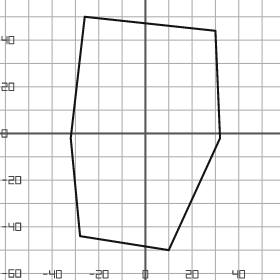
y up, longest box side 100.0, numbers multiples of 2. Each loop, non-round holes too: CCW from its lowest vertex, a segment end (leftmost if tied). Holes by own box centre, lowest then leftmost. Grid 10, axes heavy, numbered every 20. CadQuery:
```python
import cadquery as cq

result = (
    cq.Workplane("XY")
    .moveTo(10.0, -50.0)
    .lineTo(32.0, -2.0)
    .lineTo(30.0, 44.0)
    .lineTo(-26.0, 50.0)
    .lineTo(-32.0, -2.0)
    .lineTo(-28.0, -44.0)
    .close()
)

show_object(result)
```